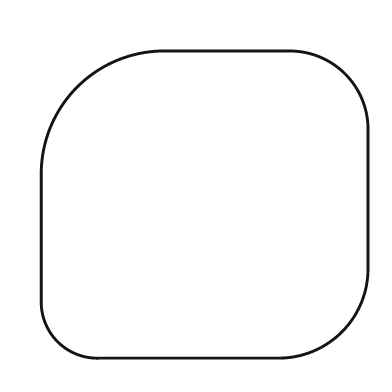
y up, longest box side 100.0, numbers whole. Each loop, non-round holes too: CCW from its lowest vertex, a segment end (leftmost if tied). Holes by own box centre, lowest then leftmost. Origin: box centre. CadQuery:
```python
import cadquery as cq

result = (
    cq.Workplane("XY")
    .moveTo(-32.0, -47.0)
    .lineTo(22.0, -47.0)
    .threePointArc((42.0, -39.0), (50.0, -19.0))
    .lineTo(50.0, 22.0)
    .threePointArc((43.0, 40.0), (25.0, 47.0))
    .lineTo(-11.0, 47.0)
    .threePointArc((-39.0, 36.0), (-50.0, 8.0))
    .lineTo(-50.0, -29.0)
    .threePointArc((-45.0, -42.0), (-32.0, -47.0))
    .close()
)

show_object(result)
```